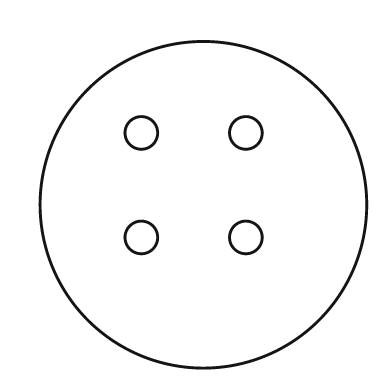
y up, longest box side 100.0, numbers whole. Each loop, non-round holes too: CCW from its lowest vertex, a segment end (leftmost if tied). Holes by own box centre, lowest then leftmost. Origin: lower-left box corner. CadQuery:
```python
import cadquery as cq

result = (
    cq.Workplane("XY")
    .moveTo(50.0, 50.0)
    .circle(50.0)
    .moveTo(31.0, 40.0)
    .circle(5.0)
    .moveTo(63.0, 40.0)
    .circle(5.0)
    .moveTo(31.0, 72.0)
    .circle(5.0)
    .moveTo(63.0, 72.0)
    .circle(5.0)
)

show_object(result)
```